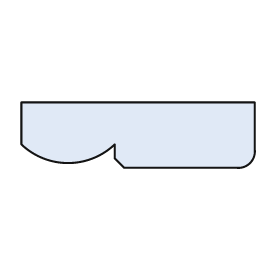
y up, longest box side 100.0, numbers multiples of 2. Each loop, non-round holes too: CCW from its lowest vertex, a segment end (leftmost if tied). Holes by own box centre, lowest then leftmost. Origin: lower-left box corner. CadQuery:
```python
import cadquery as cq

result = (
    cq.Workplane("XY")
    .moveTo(44.0, 0.0)
    .lineTo(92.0, 0.0)
    .threePointArc((98.0, 2.0), (100.0, 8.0))
    .lineTo(100.0, 28.0)
    .lineTo(0.0, 28.0)
    .lineTo(0.0, 10.0)
    .threePointArc((20.0, 2.0), (40.0, 10.0))
    .lineTo(40.0, 4.0)
    .close()
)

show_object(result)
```